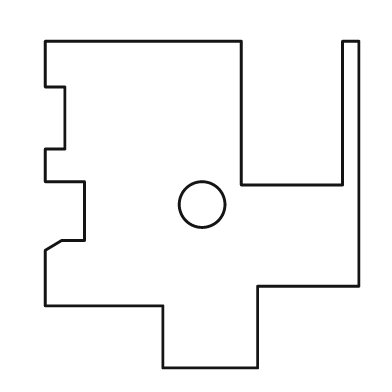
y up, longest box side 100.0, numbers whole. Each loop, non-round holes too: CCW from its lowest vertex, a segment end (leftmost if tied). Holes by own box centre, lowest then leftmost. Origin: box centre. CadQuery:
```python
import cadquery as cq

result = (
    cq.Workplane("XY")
    .moveTo(-12.0, -50.0)
    .lineTo(17.0, -50.0)
    .lineTo(17.0, -25.0)
    .lineTo(48.0, -25.0)
    .lineTo(48.0, 50.0)
    .lineTo(43.0, 50.0)
    .lineTo(43.0, 6.0)
    .lineTo(12.0, 6.0)
    .lineTo(12.0, 50.0)
    .lineTo(-48.0, 50.0)
    .lineTo(-48.0, 36.0)
    .lineTo(-42.0, 36.0)
    .lineTo(-42.0, 17.0)
    .lineTo(-48.0, 17.0)
    .lineTo(-48.0, 7.0)
    .lineTo(-36.0, 7.0)
    .lineTo(-36.0, -11.0)
    .lineTo(-43.0, -11.0)
    .lineTo(-48.0, -14.0)
    .lineTo(-48.0, -31.0)
    .lineTo(-12.0, -31.0)
    .close()
    .moveTo(0.0, 0.0)
    .circle(7.0)
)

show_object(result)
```